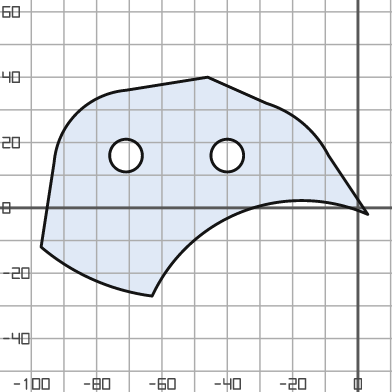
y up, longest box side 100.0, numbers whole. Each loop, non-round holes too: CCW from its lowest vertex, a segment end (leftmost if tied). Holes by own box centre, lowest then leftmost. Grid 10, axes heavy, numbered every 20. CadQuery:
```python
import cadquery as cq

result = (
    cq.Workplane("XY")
    .moveTo(-63.0, -27.0)
    .threePointArc((-35.0, -1.0), (3.0, -2.0))
    .lineTo(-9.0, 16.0)
    .threePointArc((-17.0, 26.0), (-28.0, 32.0))
    .lineTo(-46.0, 40.0)
    .lineTo(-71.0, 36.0)
    .threePointArc((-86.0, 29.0), (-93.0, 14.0))
    .lineTo(-97.0, -12.0)
    .threePointArc((-81.0, -22.0), (-63.0, -27.0))
    .close()
    .moveTo(-71.0, 16.0)
    .circle(5.0)
    .moveTo(-40.0, 16.0)
    .circle(5.0)
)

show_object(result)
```